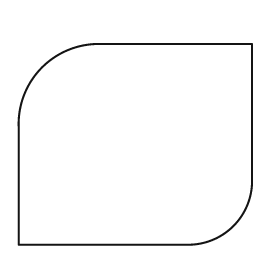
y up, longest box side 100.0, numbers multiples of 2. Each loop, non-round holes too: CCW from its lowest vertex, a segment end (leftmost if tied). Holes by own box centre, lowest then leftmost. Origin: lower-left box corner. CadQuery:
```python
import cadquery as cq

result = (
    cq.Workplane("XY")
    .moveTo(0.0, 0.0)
    .lineTo(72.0, 0.0)
    .threePointArc((92.0, 8.0), (100.0, 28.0))
    .lineTo(100.0, 86.0)
    .lineTo(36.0, 86.0)
    .threePointArc((10.0, 76.0), (0.0, 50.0))
    .close()
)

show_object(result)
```